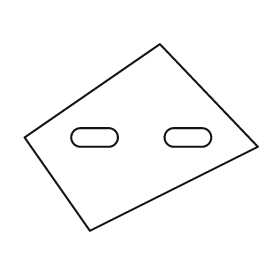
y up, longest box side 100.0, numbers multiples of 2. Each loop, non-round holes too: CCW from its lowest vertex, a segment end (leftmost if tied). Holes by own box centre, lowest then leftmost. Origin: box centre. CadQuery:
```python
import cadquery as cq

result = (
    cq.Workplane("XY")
    .moveTo(-22.0, -40.0)
    .lineTo(50.0, -4.0)
    .lineTo(8.0, 40.0)
    .lineTo(-50.0, 0.0)
    .close()
    .moveTo(-26.0, -4.0)
    .lineTo(-14.0, -4.0)
    .threePointArc((-10.0, 0.0), (-14.0, 4.0))
    .lineTo(-26.0, 4.0)
    .threePointArc((-30.0, 0.0), (-26.0, -4.0))
    .close()
    .moveTo(14.0, -4.0)
    .lineTo(26.0, -4.0)
    .threePointArc((30.0, 0.0), (26.0, 4.0))
    .lineTo(14.0, 4.0)
    .threePointArc((10.0, 0.0), (14.0, -4.0))
    .close()
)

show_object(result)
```